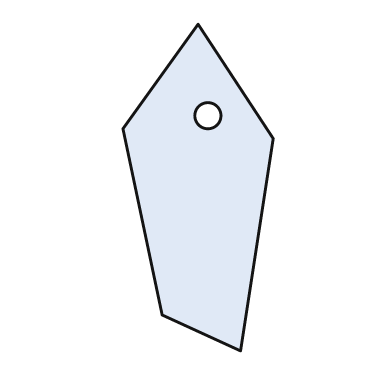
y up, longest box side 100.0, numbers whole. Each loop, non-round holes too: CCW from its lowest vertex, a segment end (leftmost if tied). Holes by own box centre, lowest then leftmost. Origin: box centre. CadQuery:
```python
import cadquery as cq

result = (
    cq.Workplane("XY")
    .moveTo(13.0, -50.0)
    .lineTo(23.0, 15.0)
    .lineTo(0.0, 50.0)
    .lineTo(-23.0, 18.0)
    .lineTo(-11.0, -39.0)
    .close()
    .moveTo(3.0, 22.0)
    .circle(4.0)
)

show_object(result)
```